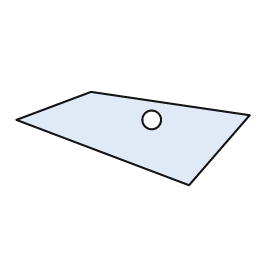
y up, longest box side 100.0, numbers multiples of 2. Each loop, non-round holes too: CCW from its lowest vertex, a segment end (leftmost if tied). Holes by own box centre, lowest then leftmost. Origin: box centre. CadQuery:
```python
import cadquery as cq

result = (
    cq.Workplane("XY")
    .moveTo(24.0, -20.0)
    .lineTo(50.0, 10.0)
    .lineTo(-18.0, 20.0)
    .lineTo(-50.0, 8.0)
    .close()
    .moveTo(8.0, 8.0)
    .circle(4.0)
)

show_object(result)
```